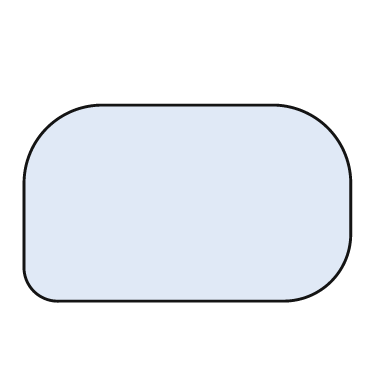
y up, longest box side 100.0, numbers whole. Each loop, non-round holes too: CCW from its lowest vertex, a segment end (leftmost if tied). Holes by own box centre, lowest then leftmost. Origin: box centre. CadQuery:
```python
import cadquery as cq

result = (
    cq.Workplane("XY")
    .moveTo(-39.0, -30.0)
    .lineTo(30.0, -30.0)
    .threePointArc((44.0, -24.0), (50.0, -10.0))
    .lineTo(50.0, 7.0)
    .threePointArc((43.0, 23.0), (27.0, 30.0))
    .lineTo(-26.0, 30.0)
    .threePointArc((-43.0, 23.0), (-50.0, 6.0))
    .lineTo(-50.0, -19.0)
    .threePointArc((-47.0, -27.0), (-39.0, -30.0))
    .close()
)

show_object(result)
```